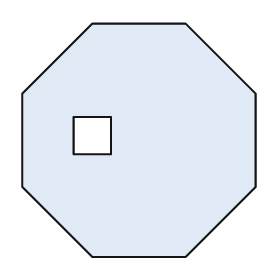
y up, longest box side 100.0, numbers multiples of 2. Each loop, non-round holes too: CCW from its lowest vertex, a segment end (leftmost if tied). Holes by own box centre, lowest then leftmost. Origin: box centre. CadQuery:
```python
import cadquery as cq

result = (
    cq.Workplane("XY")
    .moveTo(-20.0, -50.0)
    .lineTo(20.0, -50.0)
    .lineTo(50.0, -20.0)
    .lineTo(50.0, 20.0)
    .lineTo(20.0, 50.0)
    .lineTo(-20.0, 50.0)
    .lineTo(-50.0, 20.0)
    .lineTo(-50.0, -20.0)
    .close()
    .moveTo(-28.0, -6.0)
    .lineTo(-12.0, -6.0)
    .lineTo(-12.0, 10.0)
    .lineTo(-28.0, 10.0)
    .close()
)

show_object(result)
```